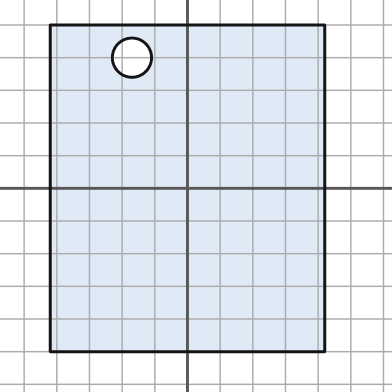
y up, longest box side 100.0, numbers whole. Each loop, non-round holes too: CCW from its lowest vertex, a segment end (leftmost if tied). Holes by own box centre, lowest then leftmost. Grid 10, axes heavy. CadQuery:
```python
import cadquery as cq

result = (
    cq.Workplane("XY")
    .moveTo(-42.0, -50.0)
    .lineTo(42.0, -50.0)
    .lineTo(42.0, 50.0)
    .lineTo(-42.0, 50.0)
    .close()
    .moveTo(-17.0, 40.0)
    .circle(6.0)
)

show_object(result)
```